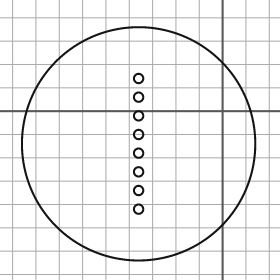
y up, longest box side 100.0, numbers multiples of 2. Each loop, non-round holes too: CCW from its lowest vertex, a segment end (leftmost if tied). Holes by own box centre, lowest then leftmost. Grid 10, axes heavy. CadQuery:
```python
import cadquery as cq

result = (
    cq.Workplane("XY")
    .moveTo(-36.0, -14.0)
    .circle(50.0)
    .moveTo(-36.0, -42.0)
    .circle(2.0)
    .moveTo(-36.0, -34.0)
    .circle(2.0)
    .moveTo(-36.0, -26.0)
    .circle(2.0)
    .moveTo(-36.0, -18.0)
    .circle(2.0)
    .moveTo(-36.0, -10.0)
    .circle(2.0)
    .moveTo(-36.0, -2.0)
    .circle(2.0)
    .moveTo(-36.0, 6.0)
    .circle(2.0)
    .moveTo(-36.0, 14.0)
    .circle(2.0)
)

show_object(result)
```